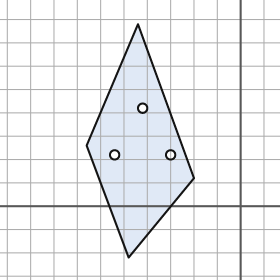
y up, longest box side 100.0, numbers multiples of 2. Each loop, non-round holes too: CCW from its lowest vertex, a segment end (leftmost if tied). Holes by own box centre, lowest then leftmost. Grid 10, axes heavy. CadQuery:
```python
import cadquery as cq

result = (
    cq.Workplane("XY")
    .moveTo(-48.0, -22.0)
    .lineTo(-20.0, 12.0)
    .lineTo(-44.0, 78.0)
    .lineTo(-66.0, 26.0)
    .close()
    .moveTo(-54.0, 22.0)
    .circle(2.0)
    .moveTo(-30.0, 22.0)
    .circle(2.0)
    .moveTo(-42.0, 42.0)
    .circle(2.0)
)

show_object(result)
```